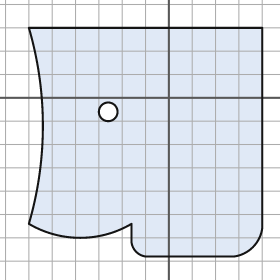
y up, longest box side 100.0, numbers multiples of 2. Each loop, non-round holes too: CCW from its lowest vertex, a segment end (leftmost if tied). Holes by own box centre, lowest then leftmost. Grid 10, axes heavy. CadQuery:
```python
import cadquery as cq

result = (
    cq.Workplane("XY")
    .moveTo(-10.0, -68.0)
    .lineTo(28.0, -68.0)
    .threePointArc((36.0, -64.0), (40.0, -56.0))
    .lineTo(40.0, 30.0)
    .lineTo(-60.0, 30.0)
    .threePointArc((-54.0, -12.0), (-60.0, -54.0))
    .threePointArc((-38.0, -60.0), (-16.0, -54.0))
    .lineTo(-16.0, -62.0)
    .threePointArc((-14.0, -66.0), (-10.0, -68.0))
    .close()
    .moveTo(-26.0, -6.0)
    .circle(4.0)
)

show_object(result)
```